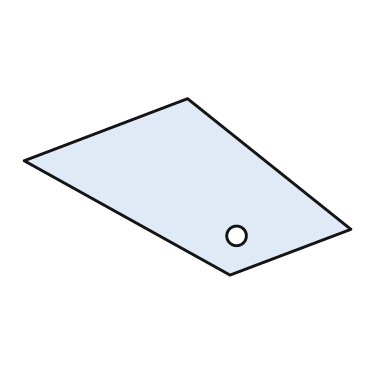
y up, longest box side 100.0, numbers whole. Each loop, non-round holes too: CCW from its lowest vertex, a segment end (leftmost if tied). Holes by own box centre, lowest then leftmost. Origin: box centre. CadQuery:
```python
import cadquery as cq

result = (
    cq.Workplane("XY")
    .moveTo(13.0, -27.0)
    .lineTo(50.0, -13.0)
    .lineTo(0.0, 27.0)
    .lineTo(-50.0, 8.0)
    .close()
    .moveTo(15.0, -15.0)
    .circle(3.0)
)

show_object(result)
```